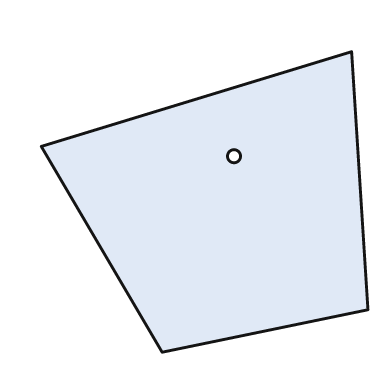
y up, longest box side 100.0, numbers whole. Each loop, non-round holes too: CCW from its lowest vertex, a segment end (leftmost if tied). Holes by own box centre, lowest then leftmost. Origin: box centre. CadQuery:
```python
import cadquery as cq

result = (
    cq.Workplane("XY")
    .moveTo(-13.0, -46.0)
    .lineTo(50.0, -33.0)
    .lineTo(45.0, 46.0)
    .lineTo(-50.0, 17.0)
    .close()
    .moveTo(9.0, 14.0)
    .circle(2.0)
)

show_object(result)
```